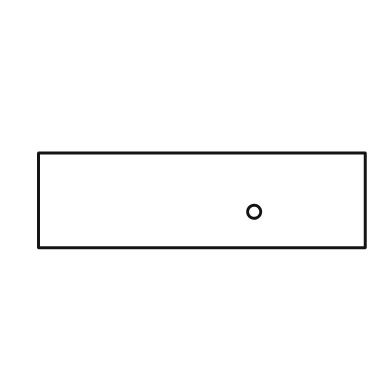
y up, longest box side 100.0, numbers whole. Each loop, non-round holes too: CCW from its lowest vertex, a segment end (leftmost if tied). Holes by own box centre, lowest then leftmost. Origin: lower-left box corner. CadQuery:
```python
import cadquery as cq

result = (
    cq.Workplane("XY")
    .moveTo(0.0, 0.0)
    .lineTo(100.0, 0.0)
    .lineTo(100.0, 29.0)
    .lineTo(0.0, 29.0)
    .close()
    .moveTo(66.0, 11.0)
    .circle(2.0)
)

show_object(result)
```